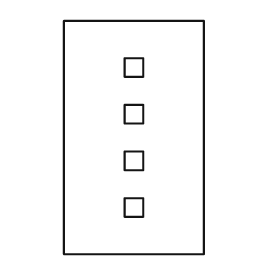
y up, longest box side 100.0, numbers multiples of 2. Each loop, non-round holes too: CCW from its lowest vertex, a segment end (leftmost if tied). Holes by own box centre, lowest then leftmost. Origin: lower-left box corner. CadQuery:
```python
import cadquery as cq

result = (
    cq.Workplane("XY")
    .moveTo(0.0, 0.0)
    .lineTo(60.0, 0.0)
    .lineTo(60.0, 100.0)
    .lineTo(0.0, 100.0)
    .close()
    .moveTo(26.0, 16.0)
    .lineTo(34.0, 16.0)
    .lineTo(34.0, 24.0)
    .lineTo(26.0, 24.0)
    .close()
    .moveTo(26.0, 36.0)
    .lineTo(34.0, 36.0)
    .lineTo(34.0, 44.0)
    .lineTo(26.0, 44.0)
    .close()
    .moveTo(26.0, 56.0)
    .lineTo(34.0, 56.0)
    .lineTo(34.0, 64.0)
    .lineTo(26.0, 64.0)
    .close()
    .moveTo(26.0, 76.0)
    .lineTo(34.0, 76.0)
    .lineTo(34.0, 84.0)
    .lineTo(26.0, 84.0)
    .close()
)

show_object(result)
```